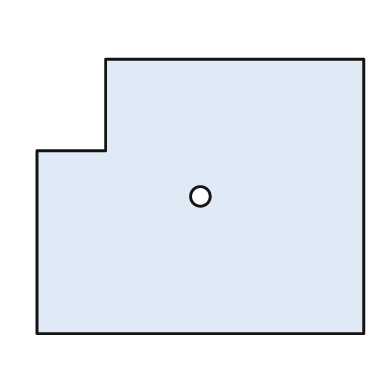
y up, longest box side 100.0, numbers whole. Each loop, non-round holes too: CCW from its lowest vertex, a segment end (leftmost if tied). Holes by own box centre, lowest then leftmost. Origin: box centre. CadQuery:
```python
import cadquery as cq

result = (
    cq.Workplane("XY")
    .moveTo(-50.0, -42.0)
    .lineTo(50.0, -42.0)
    .lineTo(50.0, 42.0)
    .lineTo(-29.0, 42.0)
    .lineTo(-29.0, 14.0)
    .lineTo(-50.0, 14.0)
    .close()
    .moveTo(0.0, 0.0)
    .circle(3.0)
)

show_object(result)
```